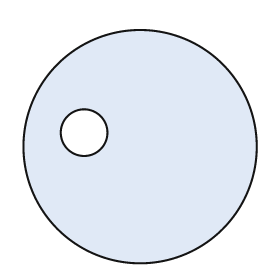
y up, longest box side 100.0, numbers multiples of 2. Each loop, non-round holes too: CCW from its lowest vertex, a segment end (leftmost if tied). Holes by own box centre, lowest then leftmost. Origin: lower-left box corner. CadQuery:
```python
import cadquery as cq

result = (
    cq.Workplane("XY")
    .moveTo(50.0, 50.0)
    .circle(50.0)
    .moveTo(26.0, 56.0)
    .circle(10.0)
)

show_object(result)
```